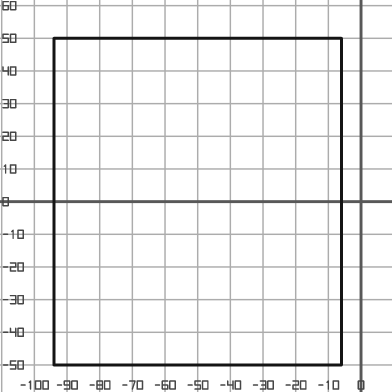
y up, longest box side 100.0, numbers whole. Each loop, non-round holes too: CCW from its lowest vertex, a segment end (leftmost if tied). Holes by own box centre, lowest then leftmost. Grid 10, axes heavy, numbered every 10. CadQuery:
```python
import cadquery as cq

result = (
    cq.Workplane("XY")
    .moveTo(-94.0, -50.0)
    .lineTo(-6.0, -50.0)
    .lineTo(-6.0, 50.0)
    .lineTo(-94.0, 50.0)
    .close()
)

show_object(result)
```